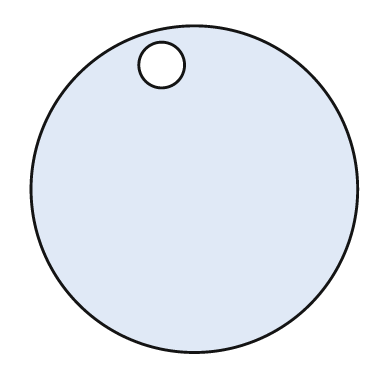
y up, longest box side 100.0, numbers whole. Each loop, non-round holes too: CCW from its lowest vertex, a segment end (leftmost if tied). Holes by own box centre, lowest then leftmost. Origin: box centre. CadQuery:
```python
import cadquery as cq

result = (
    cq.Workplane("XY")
    .moveTo(0.0, 0.0)
    .circle(50.0)
    .moveTo(-10.0, 38.0)
    .circle(7.0)
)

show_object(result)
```